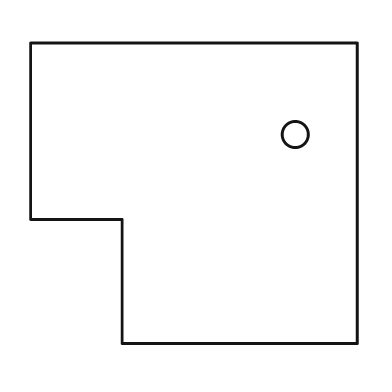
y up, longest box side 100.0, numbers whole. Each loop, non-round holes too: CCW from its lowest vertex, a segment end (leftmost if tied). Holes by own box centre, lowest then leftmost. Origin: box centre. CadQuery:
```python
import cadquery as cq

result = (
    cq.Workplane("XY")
    .moveTo(-22.0, -46.0)
    .lineTo(50.0, -46.0)
    .lineTo(50.0, 46.0)
    .lineTo(-50.0, 46.0)
    .lineTo(-50.0, -8.0)
    .lineTo(-22.0, -8.0)
    .close()
    .moveTo(31.0, 18.0)
    .circle(4.0)
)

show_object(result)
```